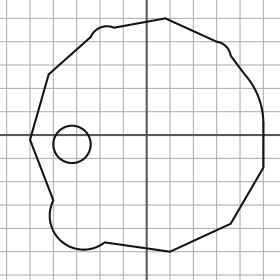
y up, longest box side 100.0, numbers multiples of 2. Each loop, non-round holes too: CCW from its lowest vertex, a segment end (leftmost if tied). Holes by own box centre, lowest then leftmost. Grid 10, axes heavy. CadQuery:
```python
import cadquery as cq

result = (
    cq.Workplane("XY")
    .moveTo(10.0, -50.0)
    .lineTo(36.0, -38.0)
    .lineTo(50.0, -14.0)
    .lineTo(50.0, 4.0)
    .threePointArc((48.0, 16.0), (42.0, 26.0))
    .lineTo(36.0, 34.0)
    .threePointArc((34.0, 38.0), (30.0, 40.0))
    .lineTo(8.0, 50.0)
    .lineTo(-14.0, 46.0)
    .threePointArc((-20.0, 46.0), (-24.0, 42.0))
    .lineTo(-42.0, 26.0)
    .lineTo(-50.0, -2.0)
    .lineTo(-40.0, -28.0)
    .threePointArc((-36.0, -46.0), (-18.0, -46.0))
    .close()
    .moveTo(-32.0, -4.0)
    .circle(8.0)
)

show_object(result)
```